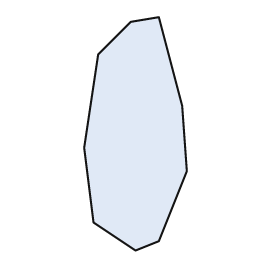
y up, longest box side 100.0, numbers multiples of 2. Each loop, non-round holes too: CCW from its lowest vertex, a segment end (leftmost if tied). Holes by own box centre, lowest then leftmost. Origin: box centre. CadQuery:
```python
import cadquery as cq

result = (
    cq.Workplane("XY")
    .moveTo(0.0, -50.0)
    .lineTo(10.0, -46.0)
    .lineTo(22.0, -16.0)
    .lineTo(20.0, 12.0)
    .lineTo(10.0, 50.0)
    .lineTo(-2.0, 48.0)
    .lineTo(-16.0, 34.0)
    .lineTo(-22.0, -6.0)
    .lineTo(-18.0, -38.0)
    .close()
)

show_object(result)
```